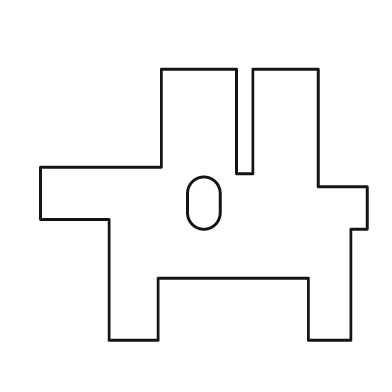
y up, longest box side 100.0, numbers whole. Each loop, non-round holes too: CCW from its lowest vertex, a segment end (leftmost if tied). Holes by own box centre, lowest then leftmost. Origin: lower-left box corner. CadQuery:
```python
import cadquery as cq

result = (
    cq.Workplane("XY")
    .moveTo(21.0, 0.0)
    .lineTo(36.0, 0.0)
    .lineTo(36.0, 19.0)
    .lineTo(82.0, 19.0)
    .lineTo(82.0, 0.0)
    .lineTo(95.0, 0.0)
    .lineTo(95.0, 34.0)
    .lineTo(100.0, 34.0)
    .lineTo(100.0, 47.0)
    .lineTo(85.0, 47.0)
    .lineTo(85.0, 83.0)
    .lineTo(65.0, 83.0)
    .lineTo(65.0, 51.0)
    .lineTo(60.0, 51.0)
    .lineTo(60.0, 83.0)
    .lineTo(37.0, 83.0)
    .lineTo(37.0, 53.0)
    .lineTo(0.0, 53.0)
    .lineTo(0.0, 37.0)
    .lineTo(21.0, 37.0)
    .close()
    .moveTo(45.0, 39.0)
    .threePointArc((50.0, 34.0), (55.0, 39.0))
    .lineTo(55.0, 45.0)
    .threePointArc((50.0, 50.0), (45.0, 45.0))
    .close()
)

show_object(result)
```